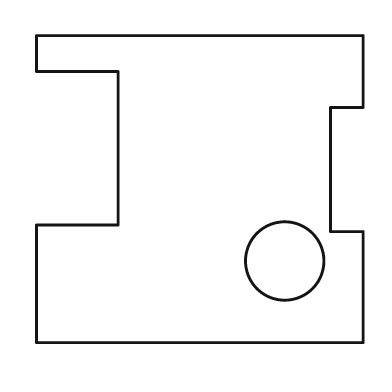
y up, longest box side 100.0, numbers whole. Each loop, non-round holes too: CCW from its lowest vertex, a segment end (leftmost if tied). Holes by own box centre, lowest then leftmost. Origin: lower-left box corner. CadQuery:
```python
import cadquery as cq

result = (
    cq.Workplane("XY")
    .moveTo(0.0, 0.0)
    .lineTo(100.0, 0.0)
    .lineTo(100.0, 34.0)
    .lineTo(90.0, 34.0)
    .lineTo(90.0, 72.0)
    .lineTo(100.0, 72.0)
    .lineTo(100.0, 94.0)
    .lineTo(0.0, 94.0)
    .lineTo(0.0, 83.0)
    .lineTo(25.0, 83.0)
    .lineTo(25.0, 36.0)
    .lineTo(0.0, 36.0)
    .close()
    .moveTo(76.0, 25.0)
    .circle(12.0)
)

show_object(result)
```